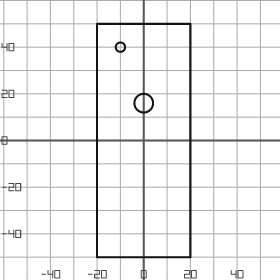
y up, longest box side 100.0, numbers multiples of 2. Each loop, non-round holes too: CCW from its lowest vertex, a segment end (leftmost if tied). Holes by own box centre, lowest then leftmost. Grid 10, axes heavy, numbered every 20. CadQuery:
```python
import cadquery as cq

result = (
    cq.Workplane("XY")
    .moveTo(-20.0, -50.0)
    .lineTo(20.0, -50.0)
    .lineTo(20.0, 50.0)
    .lineTo(-20.0, 50.0)
    .close()
    .moveTo(0.0, 16.0)
    .circle(4.0)
    .moveTo(-10.0, 40.0)
    .circle(2.0)
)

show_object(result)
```